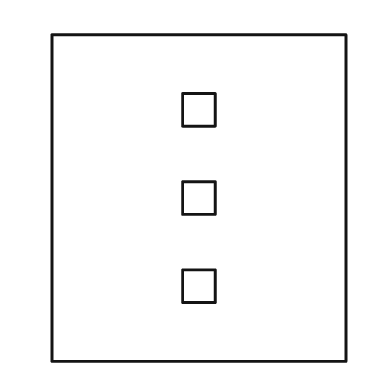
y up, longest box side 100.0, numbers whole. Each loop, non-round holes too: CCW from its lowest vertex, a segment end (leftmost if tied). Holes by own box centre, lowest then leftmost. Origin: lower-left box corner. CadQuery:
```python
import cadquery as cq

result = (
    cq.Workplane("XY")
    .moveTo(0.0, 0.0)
    .lineTo(90.0, 0.0)
    .lineTo(90.0, 100.0)
    .lineTo(0.0, 100.0)
    .close()
    .moveTo(40.0, 18.0)
    .lineTo(50.0, 18.0)
    .lineTo(50.0, 28.0)
    .lineTo(40.0, 28.0)
    .close()
    .moveTo(40.0, 45.0)
    .lineTo(50.0, 45.0)
    .lineTo(50.0, 55.0)
    .lineTo(40.0, 55.0)
    .close()
    .moveTo(40.0, 72.0)
    .lineTo(50.0, 72.0)
    .lineTo(50.0, 82.0)
    .lineTo(40.0, 82.0)
    .close()
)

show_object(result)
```